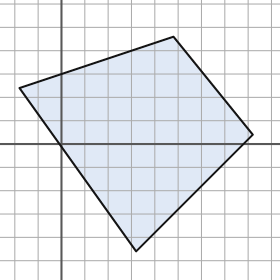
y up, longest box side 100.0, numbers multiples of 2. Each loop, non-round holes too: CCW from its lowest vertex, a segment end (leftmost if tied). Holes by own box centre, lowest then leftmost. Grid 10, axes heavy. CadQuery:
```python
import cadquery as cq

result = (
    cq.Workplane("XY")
    .moveTo(32.0, -46.0)
    .lineTo(82.0, 4.0)
    .lineTo(48.0, 46.0)
    .lineTo(-18.0, 24.0)
    .close()
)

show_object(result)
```